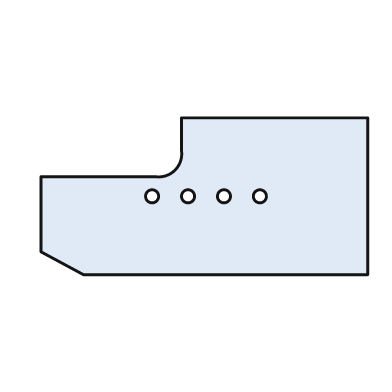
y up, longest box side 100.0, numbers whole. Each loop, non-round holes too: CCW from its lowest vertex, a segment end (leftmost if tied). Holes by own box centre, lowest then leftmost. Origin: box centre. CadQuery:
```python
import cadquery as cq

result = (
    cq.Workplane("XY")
    .moveTo(-37.0, -24.0)
    .lineTo(50.0, -24.0)
    .lineTo(50.0, 24.0)
    .lineTo(-7.0, 24.0)
    .lineTo(-7.0, 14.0)
    .threePointArc((-9.0, 8.0), (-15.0, 6.0))
    .lineTo(-50.0, 6.0)
    .lineTo(-50.0, -17.0)
    .close()
    .moveTo(-16.0, 0.0)
    .circle(2.0)
    .moveTo(-5.0, 0.0)
    .circle(2.0)
    .moveTo(6.0, 0.0)
    .circle(2.0)
    .moveTo(17.0, 0.0)
    .circle(2.0)
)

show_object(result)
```